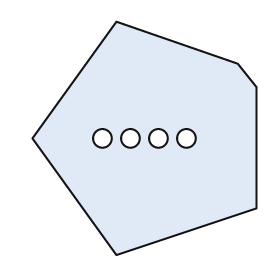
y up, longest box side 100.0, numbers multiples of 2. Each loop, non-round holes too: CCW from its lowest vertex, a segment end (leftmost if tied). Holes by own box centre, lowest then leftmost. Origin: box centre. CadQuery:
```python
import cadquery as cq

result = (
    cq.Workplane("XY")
    .moveTo(-12.0, -50.0)
    .lineTo(48.0, -30.0)
    .lineTo(48.0, 22.0)
    .lineTo(40.0, 32.0)
    .lineTo(-12.0, 50.0)
    .lineTo(-48.0, 0.0)
    .close()
    .moveTo(-18.0, 0.0)
    .circle(4.0)
    .moveTo(-6.0, 0.0)
    .circle(4.0)
    .moveTo(6.0, 0.0)
    .circle(4.0)
    .moveTo(18.0, 0.0)
    .circle(4.0)
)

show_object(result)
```